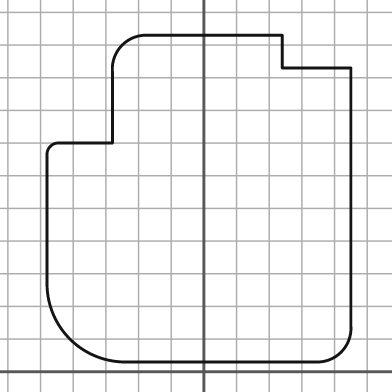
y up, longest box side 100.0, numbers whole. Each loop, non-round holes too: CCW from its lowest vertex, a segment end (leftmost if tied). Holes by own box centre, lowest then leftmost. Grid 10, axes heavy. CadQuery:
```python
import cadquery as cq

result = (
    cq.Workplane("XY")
    .moveTo(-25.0, 3.0)
    .lineTo(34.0, 3.0)
    .threePointArc((42.0, 6.0), (45.0, 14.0))
    .lineTo(45.0, 93.0)
    .lineTo(24.0, 93.0)
    .lineTo(24.0, 103.0)
    .lineTo(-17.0, 103.0)
    .threePointArc((-25.0, 100.0), (-28.0, 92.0))
    .lineTo(-28.0, 70.0)
    .lineTo(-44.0, 70.0)
    .threePointArc((-47.0, 69.0), (-48.0, 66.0))
    .lineTo(-48.0, 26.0)
    .threePointArc((-41.0, 10.0), (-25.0, 3.0))
    .close()
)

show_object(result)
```